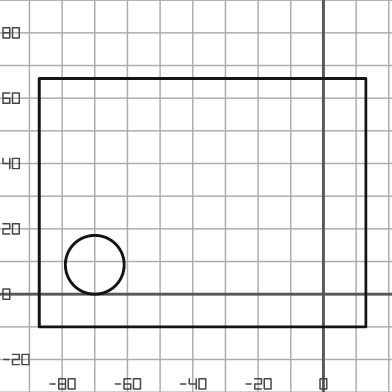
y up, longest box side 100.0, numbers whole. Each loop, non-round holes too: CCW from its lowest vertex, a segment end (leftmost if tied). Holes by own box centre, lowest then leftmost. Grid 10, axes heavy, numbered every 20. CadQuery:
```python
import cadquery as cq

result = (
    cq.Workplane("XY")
    .moveTo(-87.0, -10.0)
    .lineTo(13.0, -10.0)
    .lineTo(13.0, 66.0)
    .lineTo(-87.0, 66.0)
    .close()
    .moveTo(-70.0, 9.0)
    .circle(9.0)
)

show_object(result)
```